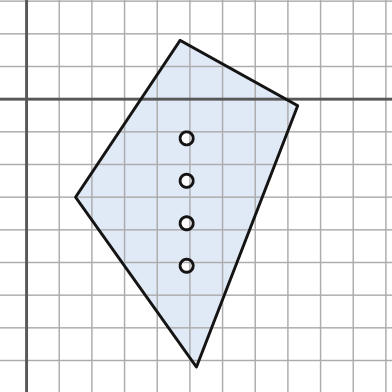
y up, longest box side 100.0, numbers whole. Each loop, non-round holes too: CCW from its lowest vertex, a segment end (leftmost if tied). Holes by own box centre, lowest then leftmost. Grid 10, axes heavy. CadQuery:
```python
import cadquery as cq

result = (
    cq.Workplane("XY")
    .moveTo(52.0, -82.0)
    .lineTo(83.0, -2.0)
    .lineTo(47.0, 18.0)
    .lineTo(15.0, -30.0)
    .close()
    .moveTo(49.0, -51.0)
    .circle(2.0)
    .moveTo(49.0, -38.0)
    .circle(2.0)
    .moveTo(49.0, -25.0)
    .circle(2.0)
    .moveTo(49.0, -12.0)
    .circle(2.0)
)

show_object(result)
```